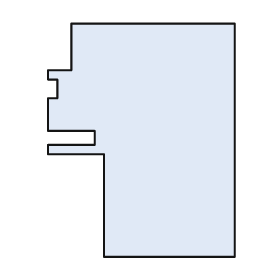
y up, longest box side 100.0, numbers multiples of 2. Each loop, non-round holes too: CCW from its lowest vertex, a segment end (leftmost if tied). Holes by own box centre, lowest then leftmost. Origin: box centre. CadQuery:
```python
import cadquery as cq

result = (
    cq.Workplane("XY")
    .moveTo(-16.0, -50.0)
    .lineTo(40.0, -50.0)
    .lineTo(40.0, 50.0)
    .lineTo(-30.0, 50.0)
    .lineTo(-30.0, 30.0)
    .lineTo(-40.0, 30.0)
    .lineTo(-40.0, 26.0)
    .lineTo(-36.0, 26.0)
    .lineTo(-36.0, 18.0)
    .lineTo(-40.0, 18.0)
    .lineTo(-40.0, 4.0)
    .lineTo(-20.0, 4.0)
    .lineTo(-20.0, -2.0)
    .lineTo(-40.0, -2.0)
    .lineTo(-40.0, -6.0)
    .lineTo(-16.0, -6.0)
    .close()
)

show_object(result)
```